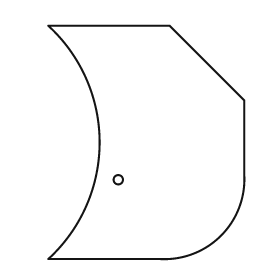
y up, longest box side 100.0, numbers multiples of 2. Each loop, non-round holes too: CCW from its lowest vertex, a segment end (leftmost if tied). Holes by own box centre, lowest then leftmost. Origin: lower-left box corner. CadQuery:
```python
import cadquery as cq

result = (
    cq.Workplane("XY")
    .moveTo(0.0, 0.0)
    .lineTo(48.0, 0.0)
    .threePointArc((74.0, 10.0), (84.0, 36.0))
    .lineTo(84.0, 68.0)
    .lineTo(52.0, 100.0)
    .lineTo(0.0, 100.0)
    .threePointArc((22.0, 50.0), (0.0, 0.0))
    .close()
    .moveTo(30.0, 34.0)
    .circle(2.0)
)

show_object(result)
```